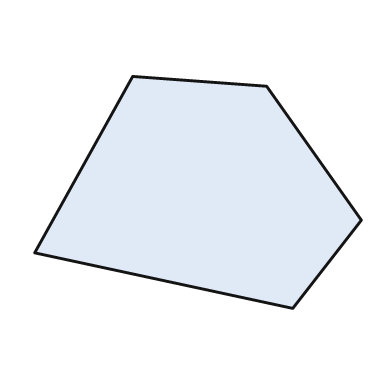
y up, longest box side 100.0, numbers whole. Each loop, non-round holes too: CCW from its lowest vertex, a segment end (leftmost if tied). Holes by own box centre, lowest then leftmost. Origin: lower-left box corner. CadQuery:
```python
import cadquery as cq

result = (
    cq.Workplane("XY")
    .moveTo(79.0, 0.0)
    .lineTo(100.0, 27.0)
    .lineTo(71.0, 68.0)
    .lineTo(30.0, 71.0)
    .lineTo(0.0, 17.0)
    .close()
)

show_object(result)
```